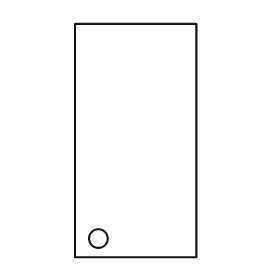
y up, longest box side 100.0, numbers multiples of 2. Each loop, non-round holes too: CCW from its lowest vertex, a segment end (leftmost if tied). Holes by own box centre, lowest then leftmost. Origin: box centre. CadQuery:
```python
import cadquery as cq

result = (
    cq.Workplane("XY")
    .moveTo(-26.0, -50.0)
    .lineTo(26.0, -50.0)
    .lineTo(26.0, 50.0)
    .lineTo(-26.0, 50.0)
    .close()
    .moveTo(-16.0, -42.0)
    .circle(4.0)
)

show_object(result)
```